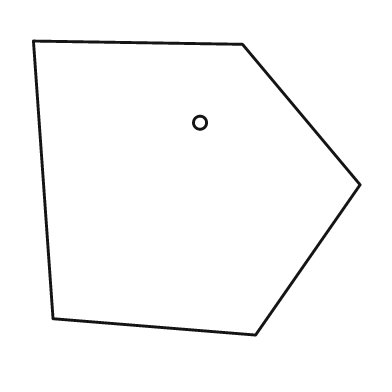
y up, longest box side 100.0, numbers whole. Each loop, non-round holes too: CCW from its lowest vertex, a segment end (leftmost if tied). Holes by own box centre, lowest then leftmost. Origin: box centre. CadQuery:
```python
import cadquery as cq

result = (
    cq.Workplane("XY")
    .moveTo(18.0, -45.0)
    .lineTo(50.0, 1.0)
    .lineTo(14.0, 44.0)
    .lineTo(-50.0, 45.0)
    .lineTo(-44.0, -40.0)
    .close()
    .moveTo(1.0, 20.0)
    .circle(2.0)
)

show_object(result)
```